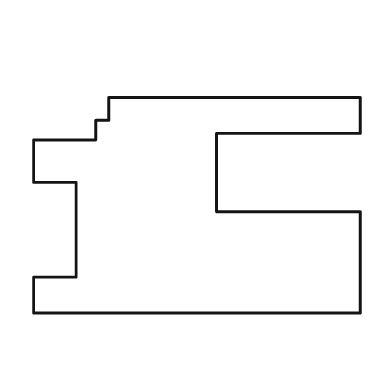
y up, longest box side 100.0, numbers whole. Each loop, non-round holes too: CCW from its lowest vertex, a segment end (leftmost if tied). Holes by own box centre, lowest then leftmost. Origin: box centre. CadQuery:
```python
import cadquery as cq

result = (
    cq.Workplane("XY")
    .moveTo(-50.0, -33.0)
    .lineTo(50.0, -33.0)
    .lineTo(50.0, -2.0)
    .lineTo(6.0, -2.0)
    .lineTo(6.0, 22.0)
    .lineTo(50.0, 22.0)
    .lineTo(50.0, 33.0)
    .lineTo(-27.0, 33.0)
    .lineTo(-27.0, 26.0)
    .lineTo(-31.0, 26.0)
    .lineTo(-31.0, 20.0)
    .lineTo(-50.0, 20.0)
    .lineTo(-50.0, 7.0)
    .lineTo(-37.0, 7.0)
    .lineTo(-37.0, -22.0)
    .lineTo(-50.0, -22.0)
    .close()
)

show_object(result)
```